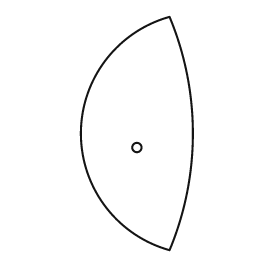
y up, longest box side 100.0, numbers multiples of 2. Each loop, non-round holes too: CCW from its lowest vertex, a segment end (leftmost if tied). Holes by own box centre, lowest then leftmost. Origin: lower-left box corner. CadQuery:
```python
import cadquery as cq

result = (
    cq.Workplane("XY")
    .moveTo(38.0, 0.0)
    .threePointArc((48.0, 50.0), (38.0, 100.0))
    .threePointArc((0.0, 50.0), (38.0, 0.0))
    .close()
    .moveTo(24.0, 44.0)
    .circle(2.0)
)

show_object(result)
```